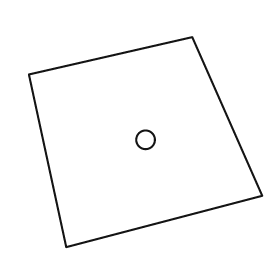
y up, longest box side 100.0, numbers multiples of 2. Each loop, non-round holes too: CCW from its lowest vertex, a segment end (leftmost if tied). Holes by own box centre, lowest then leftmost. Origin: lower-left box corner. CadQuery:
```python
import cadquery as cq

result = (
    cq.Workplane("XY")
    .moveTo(16.0, 0.0)
    .lineTo(100.0, 22.0)
    .lineTo(70.0, 90.0)
    .lineTo(0.0, 74.0)
    .close()
    .moveTo(50.0, 46.0)
    .circle(4.0)
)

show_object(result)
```